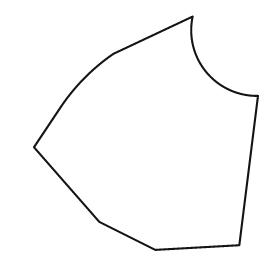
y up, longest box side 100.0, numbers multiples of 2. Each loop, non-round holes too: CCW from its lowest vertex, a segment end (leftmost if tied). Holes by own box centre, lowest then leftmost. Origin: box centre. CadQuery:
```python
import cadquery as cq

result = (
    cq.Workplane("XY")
    .moveTo(4.0, -50.0)
    .lineTo(40.0, -48.0)
    .lineTo(48.0, 16.0)
    .threePointArc((26.0, 26.0), (20.0, 50.0))
    .lineTo(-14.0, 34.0)
    .threePointArc((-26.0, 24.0), (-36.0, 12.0))
    .lineTo(-48.0, -6.0)
    .lineTo(-20.0, -38.0)
    .close()
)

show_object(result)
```